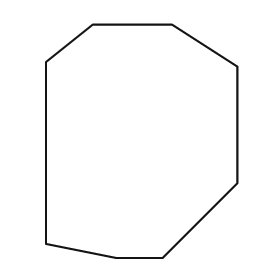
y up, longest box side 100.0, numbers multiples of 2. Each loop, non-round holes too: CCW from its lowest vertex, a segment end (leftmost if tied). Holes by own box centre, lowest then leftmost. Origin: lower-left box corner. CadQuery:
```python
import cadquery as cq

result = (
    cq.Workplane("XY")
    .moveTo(30.0, 0.0)
    .lineTo(50.0, 0.0)
    .lineTo(82.0, 32.0)
    .lineTo(82.0, 82.0)
    .lineTo(54.0, 100.0)
    .lineTo(20.0, 100.0)
    .lineTo(0.0, 84.0)
    .lineTo(0.0, 6.0)
    .close()
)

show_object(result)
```